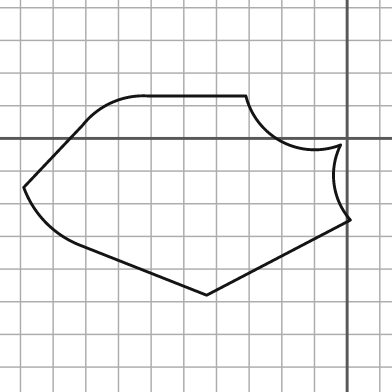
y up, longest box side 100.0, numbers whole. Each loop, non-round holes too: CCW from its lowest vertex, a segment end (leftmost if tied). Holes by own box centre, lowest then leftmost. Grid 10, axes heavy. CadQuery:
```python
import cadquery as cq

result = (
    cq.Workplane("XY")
    .moveTo(-43.0, -48.0)
    .lineTo(1.0, -25.0)
    .threePointArc((-4.0, -14.0), (-2.0, -2.0))
    .threePointArc((-20.0, -1.0), (-31.0, 13.0))
    .lineTo(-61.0, 13.0)
    .threePointArc((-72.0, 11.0), (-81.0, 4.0))
    .lineTo(-99.0, -15.0)
    .threePointArc((-92.0, -26.0), (-81.0, -33.0))
    .close()
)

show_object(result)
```